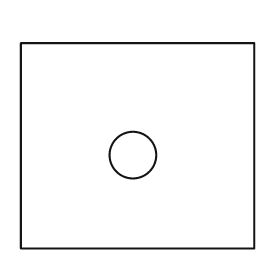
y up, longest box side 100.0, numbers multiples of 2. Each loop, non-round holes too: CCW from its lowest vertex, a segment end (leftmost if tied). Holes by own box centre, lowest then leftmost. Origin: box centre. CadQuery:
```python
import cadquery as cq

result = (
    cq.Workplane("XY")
    .moveTo(-50.0, -44.0)
    .lineTo(50.0, -44.0)
    .lineTo(50.0, 44.0)
    .lineTo(-50.0, 44.0)
    .close()
    .moveTo(-2.0, -4.0)
    .circle(10.0)
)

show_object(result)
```